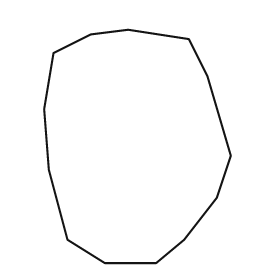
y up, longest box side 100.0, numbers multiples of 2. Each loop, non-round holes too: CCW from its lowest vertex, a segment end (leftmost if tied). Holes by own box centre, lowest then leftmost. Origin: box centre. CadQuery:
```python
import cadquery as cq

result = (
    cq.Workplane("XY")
    .moveTo(-14.0, -50.0)
    .lineTo(8.0, -50.0)
    .lineTo(20.0, -40.0)
    .lineTo(34.0, -22.0)
    .lineTo(40.0, -4.0)
    .lineTo(30.0, 30.0)
    .lineTo(22.0, 46.0)
    .lineTo(-4.0, 50.0)
    .lineTo(-20.0, 48.0)
    .lineTo(-36.0, 40.0)
    .lineTo(-40.0, 16.0)
    .lineTo(-38.0, -10.0)
    .lineTo(-30.0, -40.0)
    .close()
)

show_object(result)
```